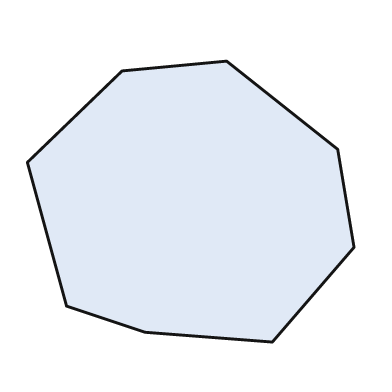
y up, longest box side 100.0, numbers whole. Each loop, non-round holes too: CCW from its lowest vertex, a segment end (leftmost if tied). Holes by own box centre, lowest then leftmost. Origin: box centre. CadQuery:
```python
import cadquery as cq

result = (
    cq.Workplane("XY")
    .moveTo(25.0, -43.0)
    .lineTo(50.0, -14.0)
    .lineTo(45.0, 16.0)
    .lineTo(11.0, 43.0)
    .lineTo(-21.0, 40.0)
    .lineTo(-50.0, 12.0)
    .lineTo(-38.0, -32.0)
    .lineTo(-14.0, -40.0)
    .close()
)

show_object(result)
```